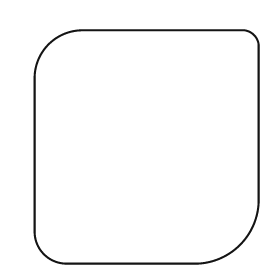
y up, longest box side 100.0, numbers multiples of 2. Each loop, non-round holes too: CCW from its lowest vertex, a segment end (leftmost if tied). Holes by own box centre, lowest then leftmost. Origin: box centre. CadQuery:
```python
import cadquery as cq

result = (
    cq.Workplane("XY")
    .moveTo(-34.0, -50.0)
    .lineTo(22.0, -50.0)
    .threePointArc((40.0, -42.0), (48.0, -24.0))
    .lineTo(48.0, 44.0)
    .threePointArc((46.0, 48.0), (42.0, 50.0))
    .lineTo(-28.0, 50.0)
    .threePointArc((-42.0, 44.0), (-48.0, 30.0))
    .lineTo(-48.0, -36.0)
    .threePointArc((-44.0, -46.0), (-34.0, -50.0))
    .close()
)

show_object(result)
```